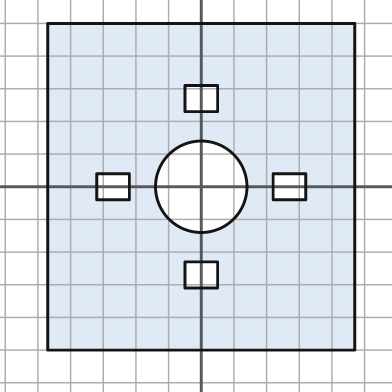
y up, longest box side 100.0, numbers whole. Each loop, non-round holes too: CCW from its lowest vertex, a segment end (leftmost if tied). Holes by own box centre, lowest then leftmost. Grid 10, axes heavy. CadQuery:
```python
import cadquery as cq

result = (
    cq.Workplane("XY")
    .moveTo(-47.0, -50.0)
    .lineTo(47.0, -50.0)
    .lineTo(47.0, 50.0)
    .lineTo(-47.0, 50.0)
    .close()
    .moveTo(-5.0, -31.0)
    .lineTo(5.0, -31.0)
    .lineTo(5.0, -23.0)
    .lineTo(-5.0, -23.0)
    .close()
    .moveTo(-32.0, -4.0)
    .lineTo(-22.0, -4.0)
    .lineTo(-22.0, 4.0)
    .lineTo(-32.0, 4.0)
    .close()
    .moveTo(0.0, 0.0)
    .circle(14.0)
    .moveTo(22.0, -4.0)
    .lineTo(32.0, -4.0)
    .lineTo(32.0, 4.0)
    .lineTo(22.0, 4.0)
    .close()
    .moveTo(-5.0, 23.0)
    .lineTo(5.0, 23.0)
    .lineTo(5.0, 31.0)
    .lineTo(-5.0, 31.0)
    .close()
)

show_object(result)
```